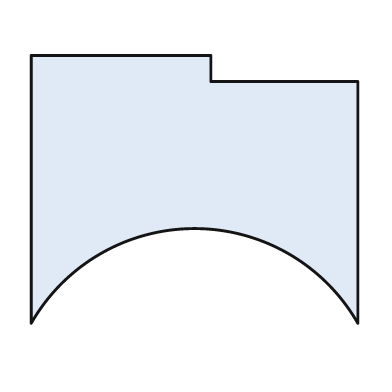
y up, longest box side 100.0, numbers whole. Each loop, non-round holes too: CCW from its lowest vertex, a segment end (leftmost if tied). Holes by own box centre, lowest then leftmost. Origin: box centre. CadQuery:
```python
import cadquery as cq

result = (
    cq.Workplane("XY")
    .moveTo(-50.0, -41.0)
    .threePointArc((0.0, -12.0), (50.0, -41.0))
    .lineTo(50.0, 33.0)
    .lineTo(5.0, 33.0)
    .lineTo(5.0, 41.0)
    .lineTo(-50.0, 41.0)
    .close()
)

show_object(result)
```